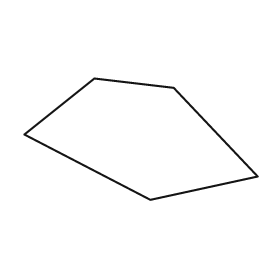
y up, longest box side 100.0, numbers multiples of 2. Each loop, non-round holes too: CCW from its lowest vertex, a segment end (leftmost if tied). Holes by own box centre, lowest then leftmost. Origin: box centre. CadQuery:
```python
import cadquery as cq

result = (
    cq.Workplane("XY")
    .moveTo(4.0, -26.0)
    .lineTo(50.0, -16.0)
    .lineTo(14.0, 22.0)
    .lineTo(-20.0, 26.0)
    .lineTo(-50.0, 2.0)
    .close()
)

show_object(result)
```